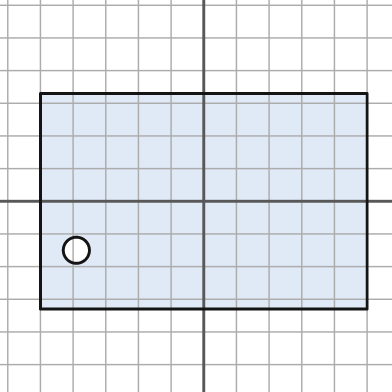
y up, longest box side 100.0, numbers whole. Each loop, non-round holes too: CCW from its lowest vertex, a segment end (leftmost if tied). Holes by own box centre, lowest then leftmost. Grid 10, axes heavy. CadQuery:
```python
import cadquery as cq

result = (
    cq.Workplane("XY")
    .moveTo(-50.0, -33.0)
    .lineTo(50.0, -33.0)
    .lineTo(50.0, 33.0)
    .lineTo(-50.0, 33.0)
    .close()
    .moveTo(-39.0, -15.0)
    .circle(4.0)
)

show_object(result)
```